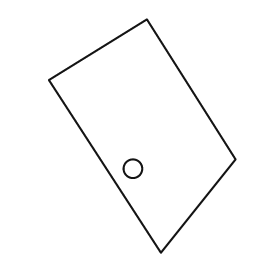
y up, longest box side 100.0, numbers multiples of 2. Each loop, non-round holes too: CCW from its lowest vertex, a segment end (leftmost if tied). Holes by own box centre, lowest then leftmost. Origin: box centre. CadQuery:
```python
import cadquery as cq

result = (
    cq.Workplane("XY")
    .moveTo(8.0, -50.0)
    .lineTo(40.0, -10.0)
    .lineTo(2.0, 50.0)
    .lineTo(-40.0, 24.0)
    .close()
    .moveTo(-4.0, -14.0)
    .circle(4.0)
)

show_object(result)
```